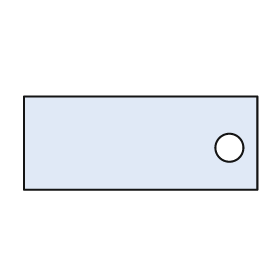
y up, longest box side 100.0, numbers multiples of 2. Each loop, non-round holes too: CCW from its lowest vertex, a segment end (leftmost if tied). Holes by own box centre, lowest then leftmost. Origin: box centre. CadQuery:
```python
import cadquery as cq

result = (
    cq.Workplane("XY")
    .moveTo(-50.0, -20.0)
    .lineTo(50.0, -20.0)
    .lineTo(50.0, 20.0)
    .lineTo(-50.0, 20.0)
    .close()
    .moveTo(38.0, -2.0)
    .circle(6.0)
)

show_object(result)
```